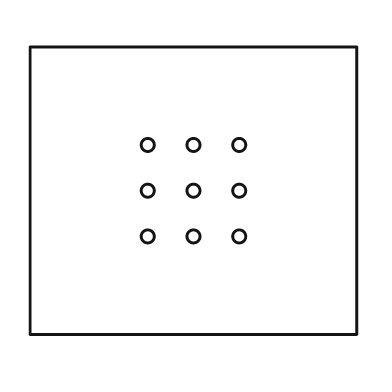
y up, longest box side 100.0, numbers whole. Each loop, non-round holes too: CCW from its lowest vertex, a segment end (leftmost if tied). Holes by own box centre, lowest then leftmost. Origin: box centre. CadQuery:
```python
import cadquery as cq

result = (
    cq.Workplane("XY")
    .moveTo(-50.0, -44.0)
    .lineTo(50.0, -44.0)
    .lineTo(50.0, 44.0)
    .lineTo(-50.0, 44.0)
    .close()
    .moveTo(-14.0, -14.0)
    .circle(2.0)
    .moveTo(0.0, -14.0)
    .circle(2.0)
    .moveTo(14.0, -14.0)
    .circle(2.0)
    .moveTo(-14.0, 0.0)
    .circle(2.0)
    .moveTo(0.0, 0.0)
    .circle(2.0)
    .moveTo(14.0, 0.0)
    .circle(2.0)
    .moveTo(-14.0, 14.0)
    .circle(2.0)
    .moveTo(0.0, 14.0)
    .circle(2.0)
    .moveTo(14.0, 14.0)
    .circle(2.0)
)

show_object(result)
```